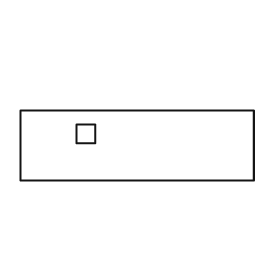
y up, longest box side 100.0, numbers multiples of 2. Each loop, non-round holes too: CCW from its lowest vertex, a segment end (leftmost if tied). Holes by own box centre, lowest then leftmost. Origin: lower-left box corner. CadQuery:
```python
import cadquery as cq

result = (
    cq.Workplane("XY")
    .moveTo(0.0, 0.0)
    .lineTo(100.0, 0.0)
    .lineTo(100.0, 30.0)
    .lineTo(0.0, 30.0)
    .close()
    .moveTo(24.0, 16.0)
    .lineTo(32.0, 16.0)
    .lineTo(32.0, 24.0)
    .lineTo(24.0, 24.0)
    .close()
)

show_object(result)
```